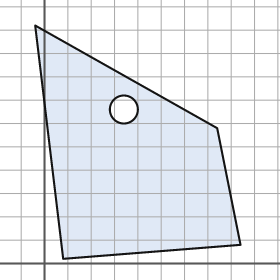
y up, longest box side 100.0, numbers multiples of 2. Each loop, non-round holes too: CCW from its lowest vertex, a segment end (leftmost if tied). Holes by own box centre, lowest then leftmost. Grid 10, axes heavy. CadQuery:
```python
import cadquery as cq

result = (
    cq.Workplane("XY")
    .moveTo(8.0, 2.0)
    .lineTo(84.0, 8.0)
    .lineTo(74.0, 58.0)
    .lineTo(-4.0, 102.0)
    .close()
    .moveTo(34.0, 66.0)
    .circle(6.0)
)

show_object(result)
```